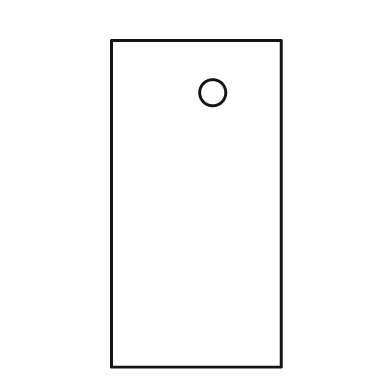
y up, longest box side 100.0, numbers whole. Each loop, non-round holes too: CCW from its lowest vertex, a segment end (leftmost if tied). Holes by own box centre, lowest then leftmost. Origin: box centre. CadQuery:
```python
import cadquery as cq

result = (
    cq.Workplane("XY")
    .moveTo(-26.0, -50.0)
    .lineTo(26.0, -50.0)
    .lineTo(26.0, 50.0)
    .lineTo(-26.0, 50.0)
    .close()
    .moveTo(5.0, 34.0)
    .circle(4.0)
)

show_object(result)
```